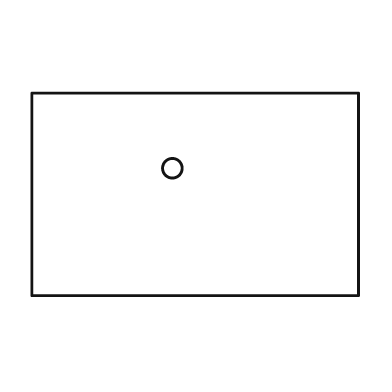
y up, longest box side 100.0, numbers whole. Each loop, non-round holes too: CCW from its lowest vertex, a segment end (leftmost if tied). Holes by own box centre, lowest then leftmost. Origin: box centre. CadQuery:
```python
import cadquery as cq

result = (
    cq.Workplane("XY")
    .moveTo(-50.0, -31.0)
    .lineTo(50.0, -31.0)
    .lineTo(50.0, 31.0)
    .lineTo(-50.0, 31.0)
    .close()
    .moveTo(-7.0, 8.0)
    .circle(3.0)
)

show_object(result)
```